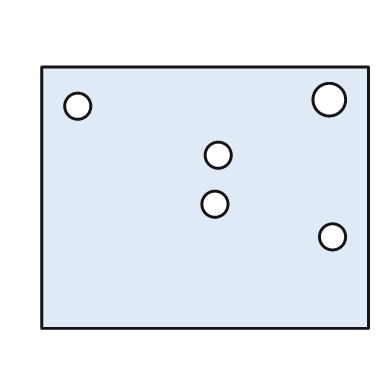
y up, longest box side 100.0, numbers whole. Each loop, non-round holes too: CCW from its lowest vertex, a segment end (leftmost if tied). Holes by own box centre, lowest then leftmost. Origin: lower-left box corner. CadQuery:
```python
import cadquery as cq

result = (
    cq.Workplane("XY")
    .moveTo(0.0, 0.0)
    .lineTo(100.0, 0.0)
    .lineTo(100.0, 80.0)
    .lineTo(0.0, 80.0)
    .close()
    .moveTo(89.0, 28.0)
    .circle(4.0)
    .moveTo(53.0, 38.0)
    .circle(4.0)
    .moveTo(54.0, 53.0)
    .circle(4.0)
    .moveTo(11.0, 68.0)
    .circle(4.0)
    .moveTo(88.0, 70.0)
    .circle(5.0)
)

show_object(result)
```